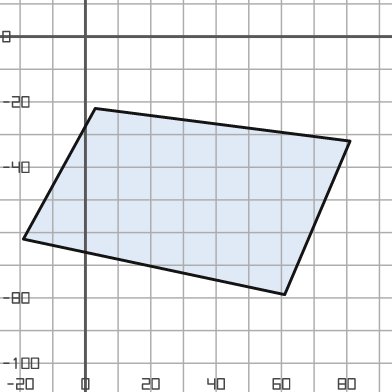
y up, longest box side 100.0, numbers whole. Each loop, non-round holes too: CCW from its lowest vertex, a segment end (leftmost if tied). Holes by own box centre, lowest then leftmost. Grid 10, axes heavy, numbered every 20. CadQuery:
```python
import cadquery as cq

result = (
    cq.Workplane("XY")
    .moveTo(61.0, -79.0)
    .lineTo(81.0, -32.0)
    .lineTo(3.0, -22.0)
    .lineTo(-19.0, -62.0)
    .close()
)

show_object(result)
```